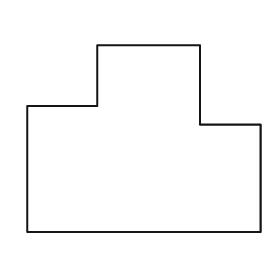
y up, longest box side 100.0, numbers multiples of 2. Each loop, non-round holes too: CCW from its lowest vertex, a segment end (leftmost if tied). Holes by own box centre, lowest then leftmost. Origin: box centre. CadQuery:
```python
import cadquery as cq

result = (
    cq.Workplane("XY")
    .moveTo(-50.0, -40.0)
    .lineTo(50.0, -40.0)
    .lineTo(50.0, 6.0)
    .lineTo(24.0, 6.0)
    .lineTo(24.0, 40.0)
    .lineTo(-20.0, 40.0)
    .lineTo(-20.0, 14.0)
    .lineTo(-50.0, 14.0)
    .close()
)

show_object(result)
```